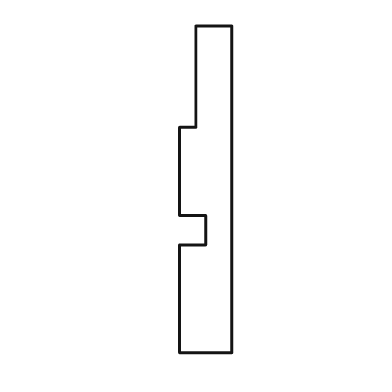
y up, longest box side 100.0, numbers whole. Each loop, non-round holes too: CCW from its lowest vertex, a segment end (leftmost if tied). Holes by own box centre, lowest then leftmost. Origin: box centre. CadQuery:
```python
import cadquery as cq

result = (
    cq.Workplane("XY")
    .moveTo(-8.0, -50.0)
    .lineTo(8.0, -50.0)
    .lineTo(8.0, 50.0)
    .lineTo(-3.0, 50.0)
    .lineTo(-3.0, 19.0)
    .lineTo(-8.0, 19.0)
    .lineTo(-8.0, -8.0)
    .lineTo(0.0, -8.0)
    .lineTo(0.0, -17.0)
    .lineTo(-8.0, -17.0)
    .close()
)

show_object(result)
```